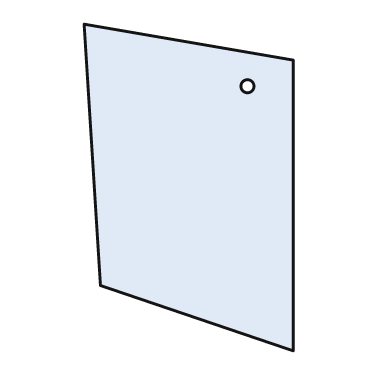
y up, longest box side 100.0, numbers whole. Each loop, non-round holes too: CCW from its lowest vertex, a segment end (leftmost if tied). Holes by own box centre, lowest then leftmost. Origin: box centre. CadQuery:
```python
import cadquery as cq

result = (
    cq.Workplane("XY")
    .moveTo(32.0, -50.0)
    .lineTo(32.0, 39.0)
    .lineTo(-32.0, 50.0)
    .lineTo(-27.0, -30.0)
    .close()
    .moveTo(18.0, 31.0)
    .circle(2.0)
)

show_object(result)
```